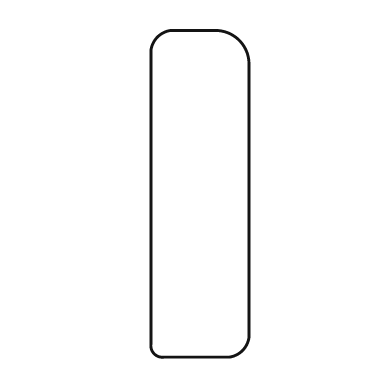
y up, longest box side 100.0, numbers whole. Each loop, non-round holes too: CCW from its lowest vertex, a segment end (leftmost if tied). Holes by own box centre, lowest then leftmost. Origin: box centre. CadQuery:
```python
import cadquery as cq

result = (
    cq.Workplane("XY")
    .moveTo(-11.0, -50.0)
    .lineTo(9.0, -50.0)
    .threePointArc((13.0, -48.0), (15.0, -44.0))
    .lineTo(15.0, 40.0)
    .threePointArc((12.0, 47.0), (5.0, 50.0))
    .lineTo(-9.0, 50.0)
    .threePointArc((-13.0, 48.0), (-15.0, 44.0))
    .lineTo(-15.0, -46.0)
    .threePointArc((-14.0, -49.0), (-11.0, -50.0))
    .close()
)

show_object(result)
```